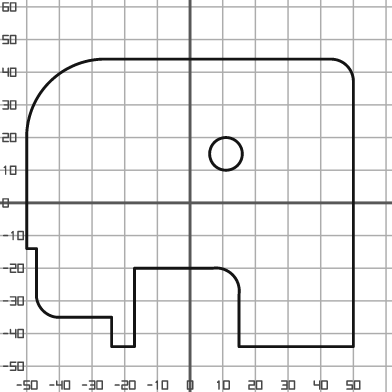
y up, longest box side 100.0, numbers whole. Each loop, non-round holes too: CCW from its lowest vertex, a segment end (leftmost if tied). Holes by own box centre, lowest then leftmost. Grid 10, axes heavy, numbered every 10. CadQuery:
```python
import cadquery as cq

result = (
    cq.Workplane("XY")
    .moveTo(-24.0, -44.0)
    .lineTo(-17.0, -44.0)
    .lineTo(-17.0, -20.0)
    .lineTo(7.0, -20.0)
    .threePointArc((13.0, -22.0), (15.0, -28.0))
    .lineTo(15.0, -44.0)
    .lineTo(50.0, -44.0)
    .lineTo(50.0, 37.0)
    .threePointArc((48.0, 42.0), (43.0, 44.0))
    .lineTo(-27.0, 44.0)
    .threePointArc((-43.0, 37.0), (-50.0, 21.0))
    .lineTo(-50.0, -14.0)
    .lineTo(-47.0, -14.0)
    .lineTo(-47.0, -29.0)
    .threePointArc((-45.0, -33.0), (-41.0, -35.0))
    .lineTo(-24.0, -35.0)
    .close()
    .moveTo(11.0, 15.0)
    .circle(5.0)
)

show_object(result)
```